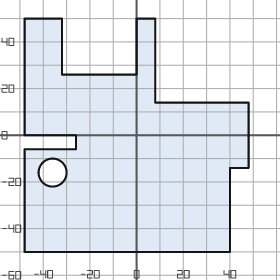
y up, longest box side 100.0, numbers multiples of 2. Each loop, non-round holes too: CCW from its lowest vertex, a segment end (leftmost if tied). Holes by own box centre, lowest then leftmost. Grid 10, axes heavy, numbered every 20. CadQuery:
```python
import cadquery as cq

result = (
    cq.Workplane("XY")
    .moveTo(-48.0, -50.0)
    .lineTo(40.0, -50.0)
    .lineTo(40.0, -14.0)
    .lineTo(48.0, -14.0)
    .lineTo(48.0, 14.0)
    .lineTo(8.0, 14.0)
    .lineTo(8.0, 50.0)
    .lineTo(0.0, 50.0)
    .lineTo(0.0, 26.0)
    .lineTo(-32.0, 26.0)
    .lineTo(-32.0, 50.0)
    .lineTo(-48.0, 50.0)
    .lineTo(-48.0, 0.0)
    .lineTo(-26.0, 0.0)
    .lineTo(-26.0, -6.0)
    .lineTo(-48.0, -6.0)
    .close()
    .moveTo(-36.0, -16.0)
    .circle(6.0)
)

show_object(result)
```